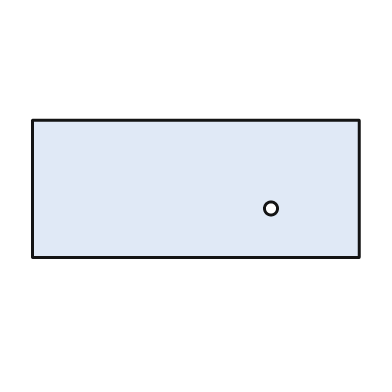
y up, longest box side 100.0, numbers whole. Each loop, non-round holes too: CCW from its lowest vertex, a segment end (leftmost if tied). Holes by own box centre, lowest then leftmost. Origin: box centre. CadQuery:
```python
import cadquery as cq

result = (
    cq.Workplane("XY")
    .moveTo(-50.0, -21.0)
    .lineTo(50.0, -21.0)
    .lineTo(50.0, 21.0)
    .lineTo(-50.0, 21.0)
    .close()
    .moveTo(23.0, -6.0)
    .circle(2.0)
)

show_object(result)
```